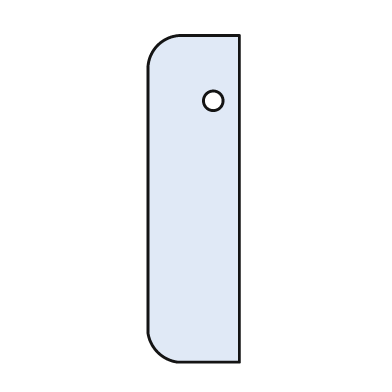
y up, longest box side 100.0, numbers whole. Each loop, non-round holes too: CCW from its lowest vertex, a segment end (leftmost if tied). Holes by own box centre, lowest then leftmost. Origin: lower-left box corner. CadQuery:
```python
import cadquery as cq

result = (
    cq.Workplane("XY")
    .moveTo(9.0, 0.0)
    .lineTo(28.0, 0.0)
    .lineTo(28.0, 100.0)
    .lineTo(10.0, 100.0)
    .threePointArc((3.0, 97.0), (0.0, 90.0))
    .lineTo(0.0, 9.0)
    .threePointArc((3.0, 3.0), (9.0, 0.0))
    .close()
    .moveTo(20.0, 80.0)
    .circle(3.0)
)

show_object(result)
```